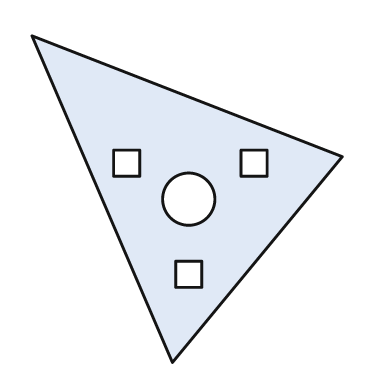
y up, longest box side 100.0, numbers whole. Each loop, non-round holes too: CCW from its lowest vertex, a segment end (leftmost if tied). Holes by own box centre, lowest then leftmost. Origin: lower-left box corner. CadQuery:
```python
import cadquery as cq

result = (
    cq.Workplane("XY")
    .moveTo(43.0, 0.0)
    .lineTo(95.0, 63.0)
    .lineTo(0.0, 100.0)
    .close()
    .moveTo(44.0, 23.0)
    .lineTo(52.0, 23.0)
    .lineTo(52.0, 31.0)
    .lineTo(44.0, 31.0)
    .close()
    .moveTo(48.0, 50.0)
    .circle(8.0)
    .moveTo(25.0, 57.0)
    .lineTo(33.0, 57.0)
    .lineTo(33.0, 65.0)
    .lineTo(25.0, 65.0)
    .close()
    .moveTo(64.0, 57.0)
    .lineTo(72.0, 57.0)
    .lineTo(72.0, 65.0)
    .lineTo(64.0, 65.0)
    .close()
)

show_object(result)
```